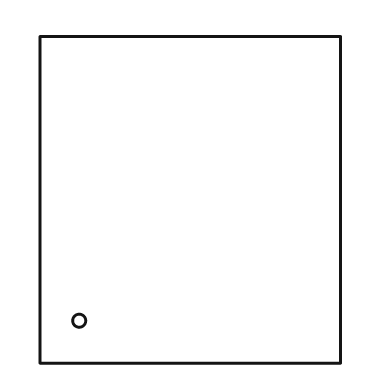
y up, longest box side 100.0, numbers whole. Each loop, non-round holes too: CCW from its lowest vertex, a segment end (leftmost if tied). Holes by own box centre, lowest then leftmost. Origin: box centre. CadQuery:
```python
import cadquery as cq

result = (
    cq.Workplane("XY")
    .moveTo(-46.0, -50.0)
    .lineTo(46.0, -50.0)
    .lineTo(46.0, 50.0)
    .lineTo(-46.0, 50.0)
    .close()
    .moveTo(-34.0, -37.0)
    .circle(2.0)
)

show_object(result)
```